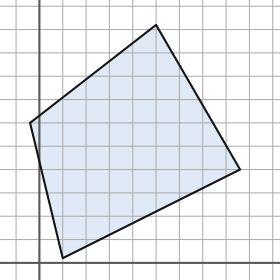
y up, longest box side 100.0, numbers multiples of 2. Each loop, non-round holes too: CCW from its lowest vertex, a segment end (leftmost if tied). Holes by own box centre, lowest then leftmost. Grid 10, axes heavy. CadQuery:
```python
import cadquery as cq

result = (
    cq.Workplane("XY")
    .moveTo(10.0, 2.0)
    .lineTo(86.0, 40.0)
    .lineTo(50.0, 102.0)
    .lineTo(-4.0, 60.0)
    .close()
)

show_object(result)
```